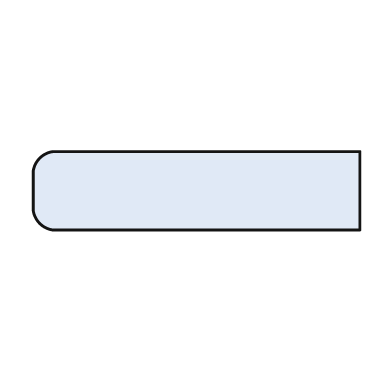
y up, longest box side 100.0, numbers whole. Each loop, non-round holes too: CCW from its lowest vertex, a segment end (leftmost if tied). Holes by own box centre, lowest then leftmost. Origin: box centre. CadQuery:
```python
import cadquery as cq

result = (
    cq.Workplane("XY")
    .moveTo(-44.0, -12.0)
    .lineTo(50.0, -12.0)
    .lineTo(50.0, 12.0)
    .lineTo(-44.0, 12.0)
    .threePointArc((-48.0, 10.0), (-50.0, 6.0))
    .lineTo(-50.0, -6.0)
    .threePointArc((-48.0, -10.0), (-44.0, -12.0))
    .close()
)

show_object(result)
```